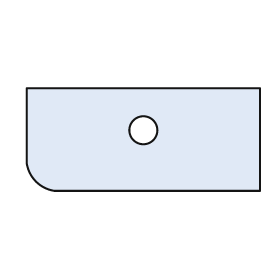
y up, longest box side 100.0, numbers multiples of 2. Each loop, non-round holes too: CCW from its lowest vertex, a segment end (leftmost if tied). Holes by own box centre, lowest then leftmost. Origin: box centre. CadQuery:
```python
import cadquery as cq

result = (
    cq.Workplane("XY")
    .moveTo(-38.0, -22.0)
    .lineTo(50.0, -22.0)
    .lineTo(50.0, 22.0)
    .lineTo(-50.0, 22.0)
    .lineTo(-50.0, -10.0)
    .threePointArc((-46.0, -18.0), (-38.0, -22.0))
    .close()
    .moveTo(0.0, 4.0)
    .circle(6.0)
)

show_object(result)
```